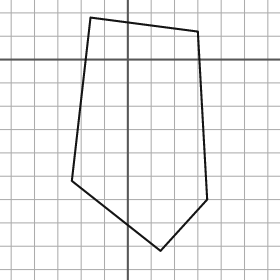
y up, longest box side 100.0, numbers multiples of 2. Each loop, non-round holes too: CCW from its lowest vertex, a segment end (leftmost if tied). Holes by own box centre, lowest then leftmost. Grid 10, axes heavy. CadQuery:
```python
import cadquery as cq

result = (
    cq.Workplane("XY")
    .moveTo(14.0, -82.0)
    .lineTo(34.0, -60.0)
    .lineTo(30.0, 12.0)
    .lineTo(-16.0, 18.0)
    .lineTo(-24.0, -52.0)
    .close()
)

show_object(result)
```